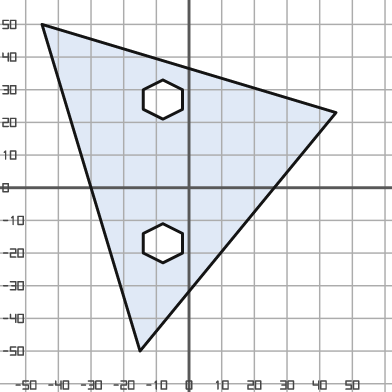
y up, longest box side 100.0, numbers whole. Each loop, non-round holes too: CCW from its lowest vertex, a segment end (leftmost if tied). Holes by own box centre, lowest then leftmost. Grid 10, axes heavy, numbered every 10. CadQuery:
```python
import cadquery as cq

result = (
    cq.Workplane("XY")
    .moveTo(-15.0, -50.0)
    .lineTo(45.0, 23.0)
    .lineTo(-45.0, 50.0)
    .close()
    .moveTo(-8.0, -23.0)
    .lineTo(-2.0, -20.0)
    .lineTo(-2.0, -14.0)
    .lineTo(-8.0, -11.0)
    .lineTo(-14.0, -14.0)
    .lineTo(-14.0, -20.0)
    .close()
    .moveTo(-8.0, 21.0)
    .lineTo(-2.0, 24.0)
    .lineTo(-2.0, 30.0)
    .lineTo(-8.0, 33.0)
    .lineTo(-14.0, 30.0)
    .lineTo(-14.0, 24.0)
    .close()
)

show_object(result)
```